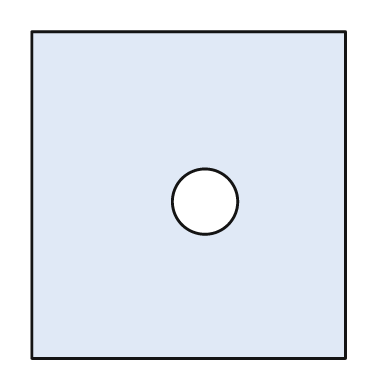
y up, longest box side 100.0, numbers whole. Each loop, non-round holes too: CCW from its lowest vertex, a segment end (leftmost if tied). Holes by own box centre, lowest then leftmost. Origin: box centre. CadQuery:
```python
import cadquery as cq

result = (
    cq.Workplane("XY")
    .moveTo(-48.0, -50.0)
    .lineTo(48.0, -50.0)
    .lineTo(48.0, 50.0)
    .lineTo(-48.0, 50.0)
    .close()
    .moveTo(5.0, -2.0)
    .circle(10.0)
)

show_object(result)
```